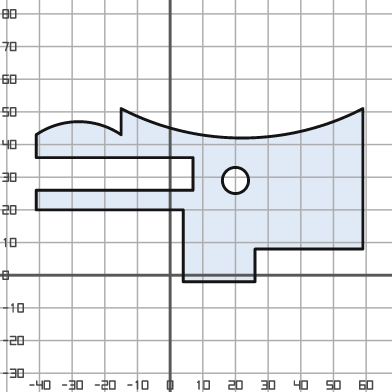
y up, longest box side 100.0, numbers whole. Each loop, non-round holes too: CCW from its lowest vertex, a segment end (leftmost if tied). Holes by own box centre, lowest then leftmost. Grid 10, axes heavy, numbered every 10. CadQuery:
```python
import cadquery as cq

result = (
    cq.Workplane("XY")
    .moveTo(4.0, -2.0)
    .lineTo(26.0, -2.0)
    .lineTo(26.0, 8.0)
    .lineTo(59.0, 8.0)
    .lineTo(59.0, 51.0)
    .threePointArc((22.0, 42.0), (-15.0, 51.0))
    .lineTo(-15.0, 43.0)
    .threePointArc((-28.0, 47.0), (-41.0, 43.0))
    .lineTo(-41.0, 36.0)
    .lineTo(7.0, 36.0)
    .lineTo(7.0, 26.0)
    .lineTo(-41.0, 26.0)
    .lineTo(-41.0, 20.0)
    .lineTo(4.0, 20.0)
    .close()
    .moveTo(20.0, 29.0)
    .circle(4.0)
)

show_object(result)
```